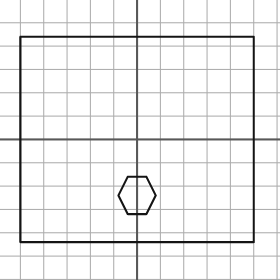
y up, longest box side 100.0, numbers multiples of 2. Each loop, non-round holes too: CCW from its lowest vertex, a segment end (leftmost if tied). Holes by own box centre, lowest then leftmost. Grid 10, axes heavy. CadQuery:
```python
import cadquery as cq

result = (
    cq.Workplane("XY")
    .moveTo(-50.0, -44.0)
    .lineTo(50.0, -44.0)
    .lineTo(50.0, 44.0)
    .lineTo(-50.0, 44.0)
    .close()
    .moveTo(-4.0, -32.0)
    .lineTo(4.0, -32.0)
    .lineTo(8.0, -24.0)
    .lineTo(4.0, -16.0)
    .lineTo(-4.0, -16.0)
    .lineTo(-8.0, -24.0)
    .close()
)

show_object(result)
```